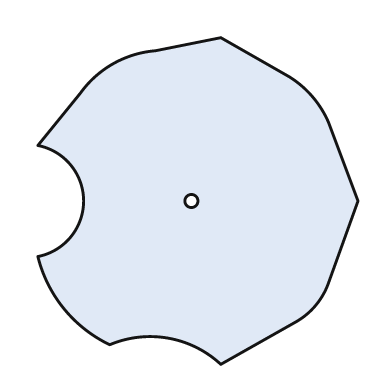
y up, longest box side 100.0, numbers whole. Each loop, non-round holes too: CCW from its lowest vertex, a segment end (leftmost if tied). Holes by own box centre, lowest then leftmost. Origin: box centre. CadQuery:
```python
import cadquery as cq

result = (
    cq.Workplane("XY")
    .moveTo(7.0, -50.0)
    .lineTo(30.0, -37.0)
    .threePointArc((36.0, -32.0), (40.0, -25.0))
    .lineTo(49.0, 0.0)
    .lineTo(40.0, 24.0)
    .threePointArc((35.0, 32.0), (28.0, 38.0))
    .lineTo(7.0, 50.0)
    .lineTo(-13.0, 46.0)
    .threePointArc((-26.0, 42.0), (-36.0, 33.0))
    .lineTo(-49.0, 17.0)
    .threePointArc((-35.0, 0.0), (-49.0, -17.0))
    .threePointArc((-41.0, -33.0), (-27.0, -44.0))
    .threePointArc((-9.0, -42.0), (7.0, -50.0))
    .close()
    .moveTo(-2.0, 0.0)
    .circle(2.0)
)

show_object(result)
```